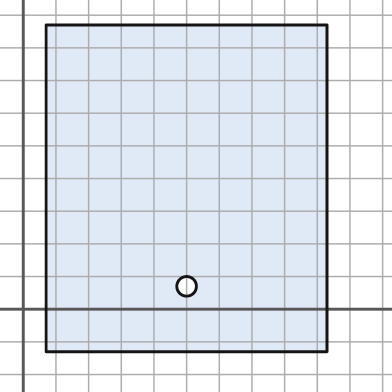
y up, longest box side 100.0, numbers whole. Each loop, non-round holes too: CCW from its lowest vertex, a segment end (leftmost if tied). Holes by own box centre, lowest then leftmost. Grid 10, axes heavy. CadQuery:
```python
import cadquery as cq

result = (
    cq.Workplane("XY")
    .moveTo(7.0, -13.0)
    .lineTo(93.0, -13.0)
    .lineTo(93.0, 87.0)
    .lineTo(7.0, 87.0)
    .close()
    .moveTo(50.0, 7.0)
    .circle(3.0)
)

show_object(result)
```